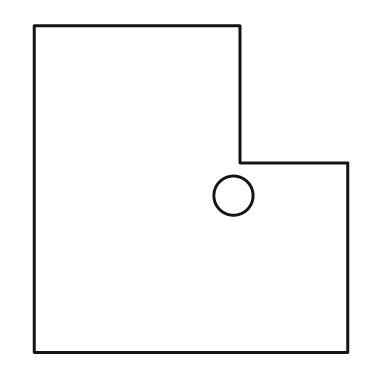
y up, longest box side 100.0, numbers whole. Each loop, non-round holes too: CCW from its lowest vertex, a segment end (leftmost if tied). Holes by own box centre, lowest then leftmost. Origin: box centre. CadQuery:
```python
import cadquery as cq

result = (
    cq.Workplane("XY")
    .moveTo(-48.0, -50.0)
    .lineTo(48.0, -50.0)
    .lineTo(48.0, 8.0)
    .lineTo(15.0, 8.0)
    .lineTo(15.0, 50.0)
    .lineTo(-48.0, 50.0)
    .close()
    .moveTo(13.0, -2.0)
    .circle(6.0)
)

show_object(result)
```